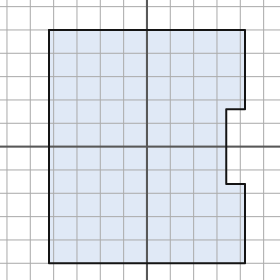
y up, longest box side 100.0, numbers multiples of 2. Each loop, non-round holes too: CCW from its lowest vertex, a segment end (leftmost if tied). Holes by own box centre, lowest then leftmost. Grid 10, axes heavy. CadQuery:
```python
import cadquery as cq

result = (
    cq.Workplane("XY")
    .moveTo(-42.0, -50.0)
    .lineTo(42.0, -50.0)
    .lineTo(42.0, -16.0)
    .lineTo(34.0, -16.0)
    .lineTo(34.0, 16.0)
    .lineTo(42.0, 16.0)
    .lineTo(42.0, 50.0)
    .lineTo(-42.0, 50.0)
    .close()
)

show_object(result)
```